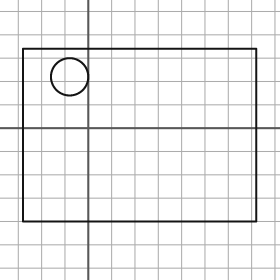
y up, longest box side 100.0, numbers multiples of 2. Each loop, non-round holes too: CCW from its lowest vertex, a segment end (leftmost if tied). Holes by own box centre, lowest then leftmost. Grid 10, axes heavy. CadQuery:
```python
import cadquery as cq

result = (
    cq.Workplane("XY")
    .moveTo(-28.0, -40.0)
    .lineTo(72.0, -40.0)
    .lineTo(72.0, 34.0)
    .lineTo(-28.0, 34.0)
    .close()
    .moveTo(-8.0, 22.0)
    .circle(8.0)
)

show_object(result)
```